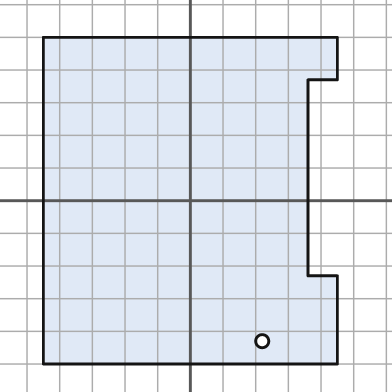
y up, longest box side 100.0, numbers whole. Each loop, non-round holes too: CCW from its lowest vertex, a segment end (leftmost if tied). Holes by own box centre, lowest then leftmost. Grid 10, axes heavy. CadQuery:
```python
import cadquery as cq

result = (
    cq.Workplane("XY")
    .moveTo(-45.0, -50.0)
    .lineTo(45.0, -50.0)
    .lineTo(45.0, -23.0)
    .lineTo(36.0, -23.0)
    .lineTo(36.0, 37.0)
    .lineTo(45.0, 37.0)
    .lineTo(45.0, 50.0)
    .lineTo(-45.0, 50.0)
    .close()
    .moveTo(22.0, -43.0)
    .circle(2.0)
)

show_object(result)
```